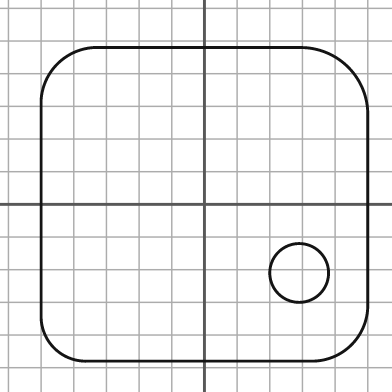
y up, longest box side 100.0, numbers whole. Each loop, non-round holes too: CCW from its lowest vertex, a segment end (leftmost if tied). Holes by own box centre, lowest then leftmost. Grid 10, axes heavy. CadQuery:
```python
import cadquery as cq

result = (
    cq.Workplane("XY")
    .moveTo(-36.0, -48.0)
    .lineTo(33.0, -48.0)
    .threePointArc((45.0, -43.0), (50.0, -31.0))
    .lineTo(50.0, 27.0)
    .threePointArc((44.0, 42.0), (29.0, 48.0))
    .lineTo(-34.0, 48.0)
    .threePointArc((-45.0, 43.0), (-50.0, 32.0))
    .lineTo(-50.0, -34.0)
    .threePointArc((-46.0, -44.0), (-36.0, -48.0))
    .close()
    .moveTo(29.0, -21.0)
    .circle(9.0)
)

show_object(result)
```